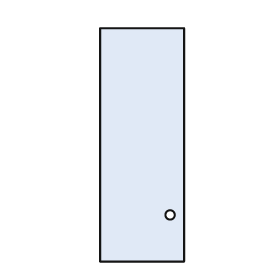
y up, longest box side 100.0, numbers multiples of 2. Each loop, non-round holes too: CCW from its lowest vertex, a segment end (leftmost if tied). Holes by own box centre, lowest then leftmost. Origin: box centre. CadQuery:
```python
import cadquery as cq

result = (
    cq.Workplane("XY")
    .moveTo(-18.0, -50.0)
    .lineTo(18.0, -50.0)
    .lineTo(18.0, 50.0)
    .lineTo(-18.0, 50.0)
    .close()
    .moveTo(12.0, -30.0)
    .circle(2.0)
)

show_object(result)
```